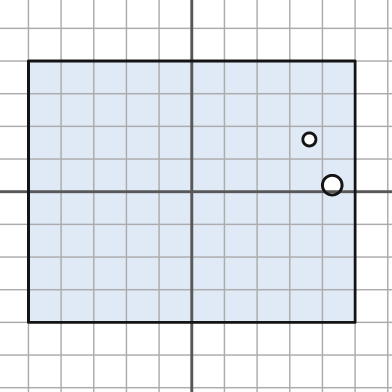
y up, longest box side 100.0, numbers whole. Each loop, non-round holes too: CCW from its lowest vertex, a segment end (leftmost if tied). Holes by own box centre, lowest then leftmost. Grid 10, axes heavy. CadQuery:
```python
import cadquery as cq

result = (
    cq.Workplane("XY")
    .moveTo(-50.0, -40.0)
    .lineTo(50.0, -40.0)
    .lineTo(50.0, 40.0)
    .lineTo(-50.0, 40.0)
    .close()
    .moveTo(43.0, 2.0)
    .circle(3.0)
    .moveTo(36.0, 16.0)
    .circle(2.0)
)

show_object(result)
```